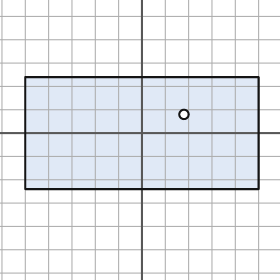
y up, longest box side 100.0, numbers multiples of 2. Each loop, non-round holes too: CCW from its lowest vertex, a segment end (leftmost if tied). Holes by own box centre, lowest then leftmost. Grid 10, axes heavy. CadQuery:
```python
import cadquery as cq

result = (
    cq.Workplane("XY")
    .moveTo(-50.0, -24.0)
    .lineTo(50.0, -24.0)
    .lineTo(50.0, 24.0)
    .lineTo(-50.0, 24.0)
    .close()
    .moveTo(18.0, 8.0)
    .circle(2.0)
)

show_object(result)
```